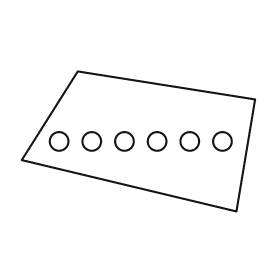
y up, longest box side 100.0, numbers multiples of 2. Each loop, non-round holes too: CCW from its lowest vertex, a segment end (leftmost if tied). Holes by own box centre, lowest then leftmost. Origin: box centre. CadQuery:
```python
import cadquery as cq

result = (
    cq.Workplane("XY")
    .moveTo(42.0, -30.0)
    .lineTo(50.0, 18.0)
    .lineTo(-26.0, 30.0)
    .lineTo(-50.0, -8.0)
    .close()
    .moveTo(-34.0, 0.0)
    .circle(4.0)
    .moveTo(-20.0, 0.0)
    .circle(4.0)
    .moveTo(-6.0, 0.0)
    .circle(4.0)
    .moveTo(8.0, 0.0)
    .circle(4.0)
    .moveTo(22.0, 0.0)
    .circle(4.0)
    .moveTo(36.0, 0.0)
    .circle(4.0)
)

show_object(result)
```